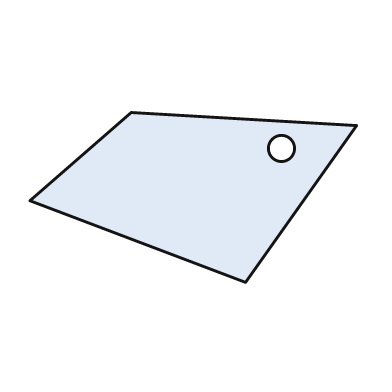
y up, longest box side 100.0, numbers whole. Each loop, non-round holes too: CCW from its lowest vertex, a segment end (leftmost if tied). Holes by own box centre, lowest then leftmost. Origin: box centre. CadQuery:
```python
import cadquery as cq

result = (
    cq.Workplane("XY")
    .moveTo(16.0, -26.0)
    .lineTo(50.0, 22.0)
    .lineTo(-19.0, 26.0)
    .lineTo(-50.0, -1.0)
    .close()
    .moveTo(27.0, 15.0)
    .circle(4.0)
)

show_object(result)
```